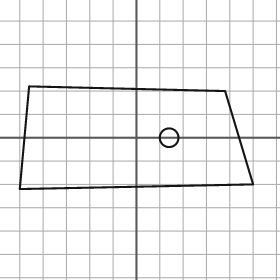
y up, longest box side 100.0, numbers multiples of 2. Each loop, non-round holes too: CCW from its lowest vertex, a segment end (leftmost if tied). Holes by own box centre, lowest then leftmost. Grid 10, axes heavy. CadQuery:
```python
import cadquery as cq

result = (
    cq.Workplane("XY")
    .moveTo(-50.0, -22.0)
    .lineTo(50.0, -20.0)
    .lineTo(38.0, 20.0)
    .lineTo(-46.0, 22.0)
    .close()
    .moveTo(14.0, 0.0)
    .circle(4.0)
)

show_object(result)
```